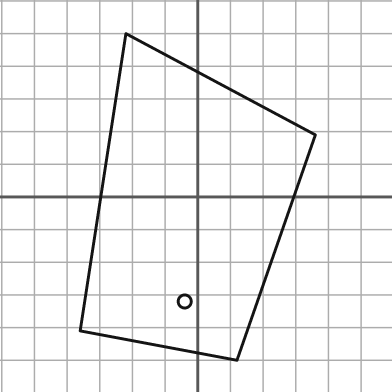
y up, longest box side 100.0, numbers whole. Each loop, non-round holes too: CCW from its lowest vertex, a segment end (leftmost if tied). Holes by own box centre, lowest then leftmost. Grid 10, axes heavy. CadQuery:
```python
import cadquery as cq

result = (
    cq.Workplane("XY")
    .moveTo(12.0, -50.0)
    .lineTo(36.0, 19.0)
    .lineTo(-22.0, 50.0)
    .lineTo(-36.0, -41.0)
    .close()
    .moveTo(-4.0, -32.0)
    .circle(2.0)
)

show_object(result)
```